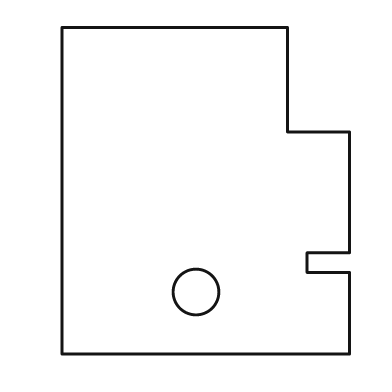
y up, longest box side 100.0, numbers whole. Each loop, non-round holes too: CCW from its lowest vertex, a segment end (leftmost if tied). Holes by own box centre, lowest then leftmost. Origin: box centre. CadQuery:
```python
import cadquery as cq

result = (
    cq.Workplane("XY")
    .moveTo(-44.0, -50.0)
    .lineTo(44.0, -50.0)
    .lineTo(44.0, -25.0)
    .lineTo(31.0, -25.0)
    .lineTo(31.0, -19.0)
    .lineTo(44.0, -19.0)
    .lineTo(44.0, 18.0)
    .lineTo(25.0, 18.0)
    .lineTo(25.0, 50.0)
    .lineTo(-44.0, 50.0)
    .close()
    .moveTo(-3.0, -31.0)
    .circle(7.0)
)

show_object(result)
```